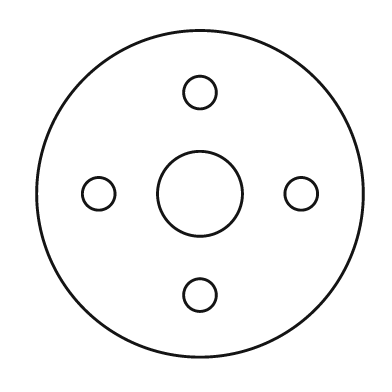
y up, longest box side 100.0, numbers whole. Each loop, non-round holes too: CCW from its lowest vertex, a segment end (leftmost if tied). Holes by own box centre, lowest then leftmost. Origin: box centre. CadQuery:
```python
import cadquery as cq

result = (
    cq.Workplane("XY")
    .moveTo(0.0, 0.0)
    .circle(50.0)
    .moveTo(0.0, -31.0)
    .circle(5.0)
    .moveTo(-31.0, 0.0)
    .circle(5.0)
    .moveTo(0.0, 0.0)
    .circle(13.0)
    .moveTo(31.0, 0.0)
    .circle(5.0)
    .moveTo(0.0, 31.0)
    .circle(5.0)
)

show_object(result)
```